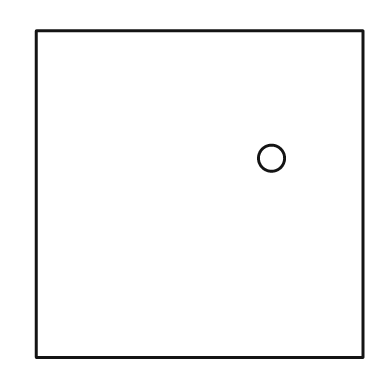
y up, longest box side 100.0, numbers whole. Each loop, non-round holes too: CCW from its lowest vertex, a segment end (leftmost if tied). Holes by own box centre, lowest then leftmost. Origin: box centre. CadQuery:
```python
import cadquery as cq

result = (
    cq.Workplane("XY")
    .moveTo(-50.0, -50.0)
    .lineTo(50.0, -50.0)
    .lineTo(50.0, 50.0)
    .lineTo(-50.0, 50.0)
    .close()
    .moveTo(22.0, 11.0)
    .circle(4.0)
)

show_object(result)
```